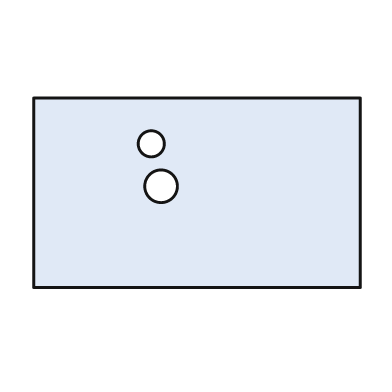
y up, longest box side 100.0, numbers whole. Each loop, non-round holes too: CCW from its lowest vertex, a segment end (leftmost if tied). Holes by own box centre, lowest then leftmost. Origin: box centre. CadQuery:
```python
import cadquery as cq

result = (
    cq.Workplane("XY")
    .moveTo(-50.0, -29.0)
    .lineTo(50.0, -29.0)
    .lineTo(50.0, 29.0)
    .lineTo(-50.0, 29.0)
    .close()
    .moveTo(-11.0, 2.0)
    .circle(5.0)
    .moveTo(-14.0, 15.0)
    .circle(4.0)
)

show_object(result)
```